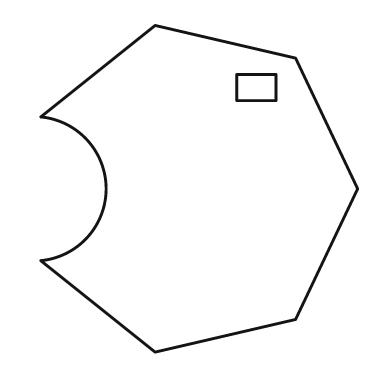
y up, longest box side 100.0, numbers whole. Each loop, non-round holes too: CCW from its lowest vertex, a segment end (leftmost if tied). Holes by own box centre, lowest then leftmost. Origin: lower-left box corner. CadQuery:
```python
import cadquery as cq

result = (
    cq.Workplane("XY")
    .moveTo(35.0, 0.0)
    .lineTo(78.0, 10.0)
    .lineTo(97.0, 50.0)
    .lineTo(78.0, 90.0)
    .lineTo(35.0, 100.0)
    .lineTo(0.0, 72.0)
    .threePointArc((20.0, 50.0), (0.0, 28.0))
    .close()
    .moveTo(60.0, 77.0)
    .lineTo(72.0, 77.0)
    .lineTo(72.0, 85.0)
    .lineTo(60.0, 85.0)
    .close()
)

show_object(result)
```